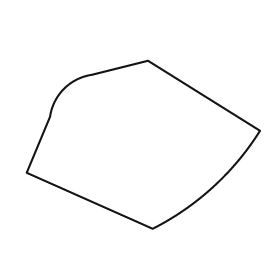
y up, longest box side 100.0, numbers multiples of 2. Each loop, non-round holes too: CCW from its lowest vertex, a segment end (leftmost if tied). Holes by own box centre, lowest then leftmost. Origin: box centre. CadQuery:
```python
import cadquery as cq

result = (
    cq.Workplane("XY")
    .moveTo(4.0, -36.0)
    .threePointArc((30.0, -18.0), (50.0, 6.0))
    .lineTo(2.0, 36.0)
    .lineTo(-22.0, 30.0)
    .threePointArc((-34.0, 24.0), (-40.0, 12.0))
    .lineTo(-50.0, -12.0)
    .close()
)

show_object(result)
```